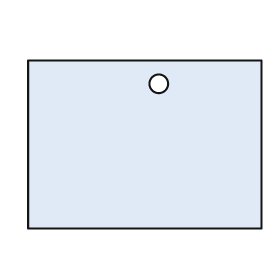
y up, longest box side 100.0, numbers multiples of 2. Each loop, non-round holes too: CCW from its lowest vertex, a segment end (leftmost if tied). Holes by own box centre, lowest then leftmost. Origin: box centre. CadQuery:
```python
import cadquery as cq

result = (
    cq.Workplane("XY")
    .moveTo(-50.0, -36.0)
    .lineTo(50.0, -36.0)
    .lineTo(50.0, 36.0)
    .lineTo(-50.0, 36.0)
    .close()
    .moveTo(6.0, 26.0)
    .circle(4.0)
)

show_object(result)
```